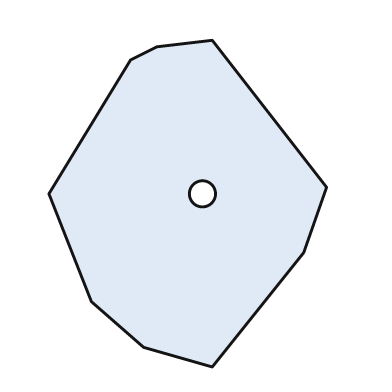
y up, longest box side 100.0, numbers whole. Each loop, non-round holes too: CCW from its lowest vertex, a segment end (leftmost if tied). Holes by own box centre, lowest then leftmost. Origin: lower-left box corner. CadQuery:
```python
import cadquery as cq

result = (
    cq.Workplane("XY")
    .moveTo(50.0, 0.0)
    .lineTo(78.0, 35.0)
    .lineTo(85.0, 55.0)
    .lineTo(50.0, 100.0)
    .lineTo(33.0, 98.0)
    .lineTo(25.0, 94.0)
    .lineTo(0.0, 53.0)
    .lineTo(13.0, 20.0)
    .lineTo(29.0, 6.0)
    .close()
    .moveTo(47.0, 53.0)
    .circle(4.0)
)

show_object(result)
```